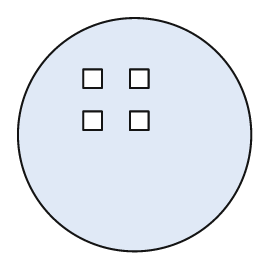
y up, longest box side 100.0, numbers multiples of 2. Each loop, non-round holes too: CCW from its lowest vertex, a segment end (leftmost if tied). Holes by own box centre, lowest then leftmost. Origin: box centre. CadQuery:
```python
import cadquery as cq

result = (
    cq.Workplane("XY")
    .moveTo(0.0, 0.0)
    .circle(50.0)
    .moveTo(-22.0, 2.0)
    .lineTo(-14.0, 2.0)
    .lineTo(-14.0, 10.0)
    .lineTo(-22.0, 10.0)
    .close()
    .moveTo(-2.0, 2.0)
    .lineTo(6.0, 2.0)
    .lineTo(6.0, 10.0)
    .lineTo(-2.0, 10.0)
    .close()
    .moveTo(-22.0, 20.0)
    .lineTo(-14.0, 20.0)
    .lineTo(-14.0, 28.0)
    .lineTo(-22.0, 28.0)
    .close()
    .moveTo(-2.0, 20.0)
    .lineTo(6.0, 20.0)
    .lineTo(6.0, 28.0)
    .lineTo(-2.0, 28.0)
    .close()
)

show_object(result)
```